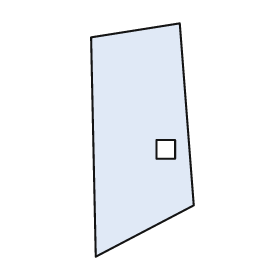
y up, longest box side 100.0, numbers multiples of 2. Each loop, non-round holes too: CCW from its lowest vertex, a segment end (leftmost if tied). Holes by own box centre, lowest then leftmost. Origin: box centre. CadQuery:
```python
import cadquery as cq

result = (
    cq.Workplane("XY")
    .moveTo(-20.0, -50.0)
    .lineTo(22.0, -28.0)
    .lineTo(16.0, 50.0)
    .lineTo(-22.0, 44.0)
    .close()
    .moveTo(6.0, -8.0)
    .lineTo(14.0, -8.0)
    .lineTo(14.0, 0.0)
    .lineTo(6.0, 0.0)
    .close()
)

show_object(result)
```